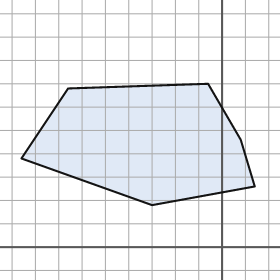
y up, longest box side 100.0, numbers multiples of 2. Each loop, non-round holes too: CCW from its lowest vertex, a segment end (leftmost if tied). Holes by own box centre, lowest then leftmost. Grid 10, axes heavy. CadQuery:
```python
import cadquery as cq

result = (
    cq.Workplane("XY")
    .moveTo(-30.0, 18.0)
    .lineTo(14.0, 26.0)
    .lineTo(8.0, 46.0)
    .lineTo(-6.0, 70.0)
    .lineTo(-66.0, 68.0)
    .lineTo(-86.0, 38.0)
    .close()
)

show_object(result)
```